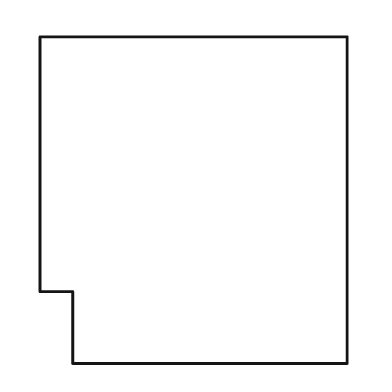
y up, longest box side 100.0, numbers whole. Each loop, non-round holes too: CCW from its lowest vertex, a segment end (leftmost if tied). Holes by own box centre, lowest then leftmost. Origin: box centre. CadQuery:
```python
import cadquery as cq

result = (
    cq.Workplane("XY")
    .moveTo(-37.0, -50.0)
    .lineTo(47.0, -50.0)
    .lineTo(47.0, 50.0)
    .lineTo(-47.0, 50.0)
    .lineTo(-47.0, -28.0)
    .lineTo(-37.0, -28.0)
    .close()
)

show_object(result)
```